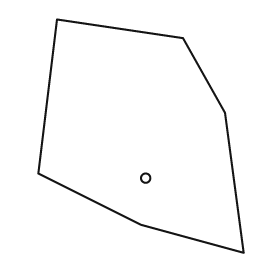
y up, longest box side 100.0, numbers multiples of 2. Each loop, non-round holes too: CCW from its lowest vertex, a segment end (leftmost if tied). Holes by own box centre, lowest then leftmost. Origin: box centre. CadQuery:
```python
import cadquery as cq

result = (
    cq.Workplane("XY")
    .moveTo(44.0, -50.0)
    .lineTo(36.0, 10.0)
    .lineTo(18.0, 42.0)
    .lineTo(-36.0, 50.0)
    .lineTo(-44.0, -16.0)
    .lineTo(0.0, -38.0)
    .close()
    .moveTo(2.0, -18.0)
    .circle(2.0)
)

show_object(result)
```